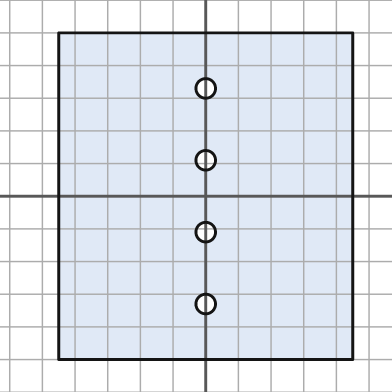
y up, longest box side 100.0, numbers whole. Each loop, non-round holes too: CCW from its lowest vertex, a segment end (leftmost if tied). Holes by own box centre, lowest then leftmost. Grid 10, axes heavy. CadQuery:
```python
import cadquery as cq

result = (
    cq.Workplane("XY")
    .moveTo(-45.0, -50.0)
    .lineTo(45.0, -50.0)
    .lineTo(45.0, 50.0)
    .lineTo(-45.0, 50.0)
    .close()
    .moveTo(0.0, -33.0)
    .circle(3.0)
    .moveTo(0.0, -11.0)
    .circle(3.0)
    .moveTo(0.0, 11.0)
    .circle(3.0)
    .moveTo(0.0, 33.0)
    .circle(3.0)
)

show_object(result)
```